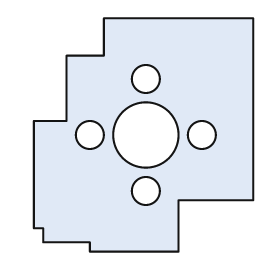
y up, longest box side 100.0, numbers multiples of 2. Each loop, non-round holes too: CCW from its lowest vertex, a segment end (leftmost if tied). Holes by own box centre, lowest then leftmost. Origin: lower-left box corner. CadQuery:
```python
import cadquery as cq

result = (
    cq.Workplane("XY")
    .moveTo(24.0, 0.0)
    .lineTo(62.0, 0.0)
    .lineTo(62.0, 22.0)
    .lineTo(94.0, 22.0)
    .lineTo(94.0, 100.0)
    .lineTo(30.0, 100.0)
    .lineTo(30.0, 84.0)
    .lineTo(14.0, 84.0)
    .lineTo(14.0, 56.0)
    .lineTo(0.0, 56.0)
    .lineTo(0.0, 10.0)
    .lineTo(4.0, 10.0)
    .lineTo(4.0, 4.0)
    .lineTo(24.0, 4.0)
    .close()
    .moveTo(48.0, 26.0)
    .circle(6.0)
    .moveTo(24.0, 50.0)
    .circle(6.0)
    .moveTo(48.0, 50.0)
    .circle(14.0)
    .moveTo(72.0, 50.0)
    .circle(6.0)
    .moveTo(48.0, 74.0)
    .circle(6.0)
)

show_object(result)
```